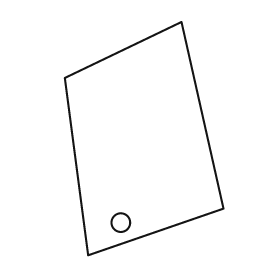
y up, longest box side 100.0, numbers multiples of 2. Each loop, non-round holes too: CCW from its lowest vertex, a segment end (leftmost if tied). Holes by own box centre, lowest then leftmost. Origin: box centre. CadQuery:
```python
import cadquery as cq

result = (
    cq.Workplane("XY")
    .moveTo(-24.0, -50.0)
    .lineTo(34.0, -30.0)
    .lineTo(16.0, 50.0)
    .lineTo(-34.0, 26.0)
    .close()
    .moveTo(-10.0, -36.0)
    .circle(4.0)
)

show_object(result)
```